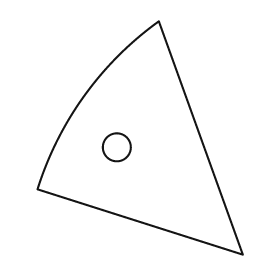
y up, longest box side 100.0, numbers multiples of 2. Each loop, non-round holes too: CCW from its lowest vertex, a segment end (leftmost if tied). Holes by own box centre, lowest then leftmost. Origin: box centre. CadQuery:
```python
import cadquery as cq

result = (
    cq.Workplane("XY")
    .moveTo(44.0, -50.0)
    .lineTo(8.0, 50.0)
    .threePointArc((-24.0, 18.0), (-44.0, -22.0))
    .close()
    .moveTo(-10.0, -4.0)
    .circle(6.0)
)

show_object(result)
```